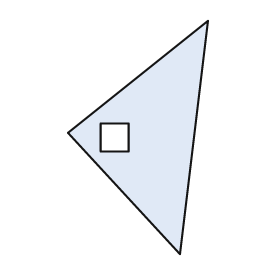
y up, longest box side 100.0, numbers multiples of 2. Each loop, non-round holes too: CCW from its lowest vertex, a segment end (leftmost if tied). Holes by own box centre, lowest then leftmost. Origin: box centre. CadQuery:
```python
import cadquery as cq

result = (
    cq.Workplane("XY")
    .moveTo(18.0, -50.0)
    .lineTo(30.0, 50.0)
    .lineTo(-30.0, 2.0)
    .close()
    .moveTo(-16.0, -6.0)
    .lineTo(-4.0, -6.0)
    .lineTo(-4.0, 6.0)
    .lineTo(-16.0, 6.0)
    .close()
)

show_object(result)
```